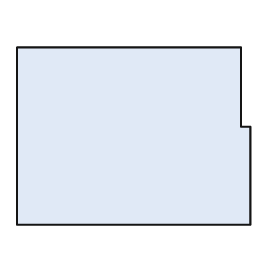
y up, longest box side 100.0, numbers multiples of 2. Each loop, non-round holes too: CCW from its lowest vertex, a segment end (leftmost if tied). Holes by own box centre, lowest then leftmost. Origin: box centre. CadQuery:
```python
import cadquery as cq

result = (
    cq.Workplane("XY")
    .moveTo(-50.0, -38.0)
    .lineTo(50.0, -38.0)
    .lineTo(50.0, 4.0)
    .lineTo(46.0, 4.0)
    .lineTo(46.0, 38.0)
    .lineTo(-50.0, 38.0)
    .close()
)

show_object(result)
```